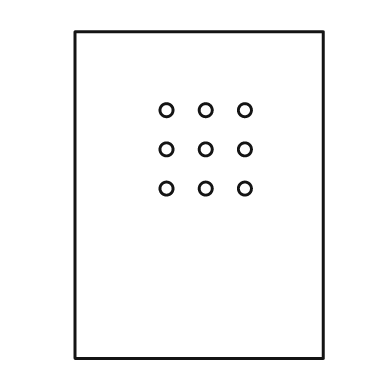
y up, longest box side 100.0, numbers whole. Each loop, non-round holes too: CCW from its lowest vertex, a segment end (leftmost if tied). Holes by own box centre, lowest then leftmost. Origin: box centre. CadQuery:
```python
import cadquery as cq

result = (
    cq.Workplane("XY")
    .moveTo(-38.0, -50.0)
    .lineTo(38.0, -50.0)
    .lineTo(38.0, 50.0)
    .lineTo(-38.0, 50.0)
    .close()
    .moveTo(-10.0, 2.0)
    .circle(2.0)
    .moveTo(2.0, 2.0)
    .circle(2.0)
    .moveTo(14.0, 2.0)
    .circle(2.0)
    .moveTo(-10.0, 14.0)
    .circle(2.0)
    .moveTo(2.0, 14.0)
    .circle(2.0)
    .moveTo(14.0, 14.0)
    .circle(2.0)
    .moveTo(-10.0, 26.0)
    .circle(2.0)
    .moveTo(2.0, 26.0)
    .circle(2.0)
    .moveTo(14.0, 26.0)
    .circle(2.0)
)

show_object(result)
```